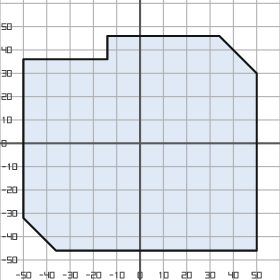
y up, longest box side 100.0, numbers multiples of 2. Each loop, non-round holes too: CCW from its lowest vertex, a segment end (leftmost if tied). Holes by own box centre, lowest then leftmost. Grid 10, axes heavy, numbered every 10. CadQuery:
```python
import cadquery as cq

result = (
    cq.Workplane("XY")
    .moveTo(-36.0, -46.0)
    .lineTo(50.0, -46.0)
    .lineTo(50.0, 30.0)
    .lineTo(34.0, 46.0)
    .lineTo(-14.0, 46.0)
    .lineTo(-14.0, 36.0)
    .lineTo(-50.0, 36.0)
    .lineTo(-50.0, -32.0)
    .close()
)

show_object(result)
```